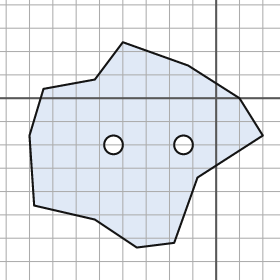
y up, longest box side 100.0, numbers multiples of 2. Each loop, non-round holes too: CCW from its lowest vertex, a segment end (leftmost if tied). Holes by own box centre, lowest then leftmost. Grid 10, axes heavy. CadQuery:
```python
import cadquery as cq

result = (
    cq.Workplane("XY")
    .moveTo(-34.0, -64.0)
    .lineTo(-18.0, -62.0)
    .lineTo(-8.0, -34.0)
    .lineTo(20.0, -16.0)
    .lineTo(10.0, 0.0)
    .lineTo(-12.0, 14.0)
    .lineTo(-40.0, 24.0)
    .lineTo(-52.0, 8.0)
    .lineTo(-74.0, 4.0)
    .lineTo(-80.0, -16.0)
    .lineTo(-78.0, -46.0)
    .lineTo(-52.0, -52.0)
    .close()
    .moveTo(-44.0, -20.0)
    .circle(4.0)
    .moveTo(-14.0, -20.0)
    .circle(4.0)
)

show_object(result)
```